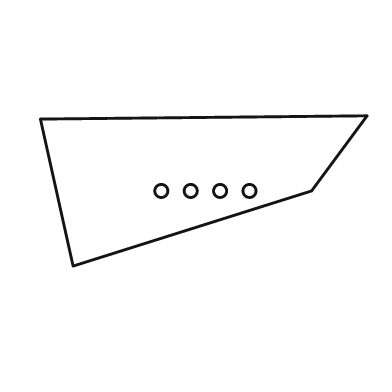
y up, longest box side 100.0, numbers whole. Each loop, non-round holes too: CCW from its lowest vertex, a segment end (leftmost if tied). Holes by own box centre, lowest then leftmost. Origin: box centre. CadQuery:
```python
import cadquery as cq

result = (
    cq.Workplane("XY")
    .moveTo(-40.0, -23.0)
    .lineTo(33.0, 0.0)
    .lineTo(50.0, 23.0)
    .lineTo(-50.0, 22.0)
    .close()
    .moveTo(-13.0, 0.0)
    .circle(2.0)
    .moveTo(-4.0, 0.0)
    .circle(2.0)
    .moveTo(5.0, 0.0)
    .circle(2.0)
    .moveTo(14.0, 0.0)
    .circle(2.0)
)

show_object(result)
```